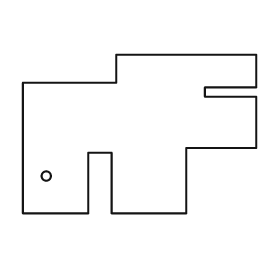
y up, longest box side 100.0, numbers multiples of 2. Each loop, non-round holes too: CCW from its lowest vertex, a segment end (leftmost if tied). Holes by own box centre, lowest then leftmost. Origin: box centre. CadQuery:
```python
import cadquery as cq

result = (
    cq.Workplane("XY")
    .moveTo(-50.0, -34.0)
    .lineTo(-22.0, -34.0)
    .lineTo(-22.0, -8.0)
    .lineTo(-12.0, -8.0)
    .lineTo(-12.0, -34.0)
    .lineTo(20.0, -34.0)
    .lineTo(20.0, -6.0)
    .lineTo(50.0, -6.0)
    .lineTo(50.0, 16.0)
    .lineTo(28.0, 16.0)
    .lineTo(28.0, 20.0)
    .lineTo(50.0, 20.0)
    .lineTo(50.0, 34.0)
    .lineTo(-10.0, 34.0)
    .lineTo(-10.0, 22.0)
    .lineTo(-50.0, 22.0)
    .close()
    .moveTo(-40.0, -18.0)
    .circle(2.0)
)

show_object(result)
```